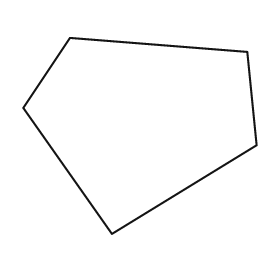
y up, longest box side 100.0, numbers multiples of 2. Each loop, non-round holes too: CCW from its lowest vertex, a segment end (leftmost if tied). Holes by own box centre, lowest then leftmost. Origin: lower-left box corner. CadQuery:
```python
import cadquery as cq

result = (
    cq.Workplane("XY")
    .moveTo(38.0, 0.0)
    .lineTo(100.0, 38.0)
    .lineTo(96.0, 78.0)
    .lineTo(20.0, 84.0)
    .lineTo(0.0, 54.0)
    .close()
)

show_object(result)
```